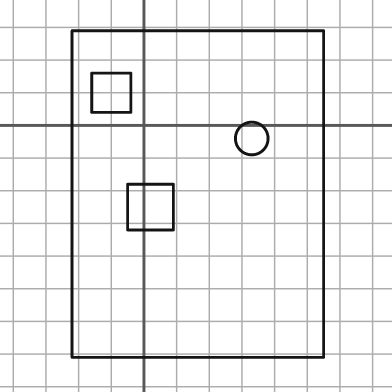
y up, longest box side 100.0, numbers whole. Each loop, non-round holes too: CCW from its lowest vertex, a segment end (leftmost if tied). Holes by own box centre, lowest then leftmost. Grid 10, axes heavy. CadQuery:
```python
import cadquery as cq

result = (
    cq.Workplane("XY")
    .moveTo(-22.0, -71.0)
    .lineTo(55.0, -71.0)
    .lineTo(55.0, 29.0)
    .lineTo(-22.0, 29.0)
    .close()
    .moveTo(-5.0, -32.0)
    .lineTo(9.0, -32.0)
    .lineTo(9.0, -18.0)
    .lineTo(-5.0, -18.0)
    .close()
    .moveTo(33.0, -4.0)
    .circle(5.0)
    .moveTo(-16.0, 4.0)
    .lineTo(-4.0, 4.0)
    .lineTo(-4.0, 16.0)
    .lineTo(-16.0, 16.0)
    .close()
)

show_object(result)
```